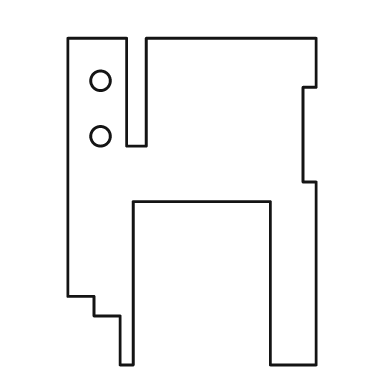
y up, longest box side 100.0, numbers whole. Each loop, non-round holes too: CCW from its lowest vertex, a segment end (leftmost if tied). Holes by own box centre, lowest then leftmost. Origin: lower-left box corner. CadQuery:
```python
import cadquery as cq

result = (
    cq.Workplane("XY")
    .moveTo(16.0, 0.0)
    .lineTo(20.0, 0.0)
    .lineTo(20.0, 50.0)
    .lineTo(62.0, 50.0)
    .lineTo(62.0, 0.0)
    .lineTo(76.0, 0.0)
    .lineTo(76.0, 56.0)
    .lineTo(72.0, 56.0)
    .lineTo(72.0, 85.0)
    .lineTo(76.0, 85.0)
    .lineTo(76.0, 100.0)
    .lineTo(24.0, 100.0)
    .lineTo(24.0, 67.0)
    .lineTo(18.0, 67.0)
    .lineTo(18.0, 100.0)
    .lineTo(0.0, 100.0)
    .lineTo(0.0, 21.0)
    .lineTo(8.0, 21.0)
    .lineTo(8.0, 15.0)
    .lineTo(16.0, 15.0)
    .close()
    .moveTo(10.0, 70.0)
    .circle(3.0)
    .moveTo(10.0, 87.0)
    .circle(3.0)
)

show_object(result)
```